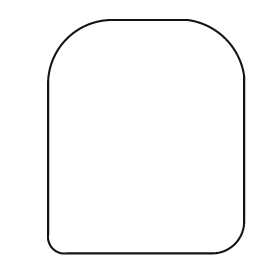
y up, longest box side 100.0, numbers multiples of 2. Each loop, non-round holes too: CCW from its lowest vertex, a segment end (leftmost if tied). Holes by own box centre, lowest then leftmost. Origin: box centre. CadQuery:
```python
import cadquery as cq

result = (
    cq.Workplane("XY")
    .moveTo(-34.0, -50.0)
    .lineTo(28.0, -50.0)
    .threePointArc((38.0, -46.0), (42.0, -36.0))
    .lineTo(42.0, 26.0)
    .threePointArc((34.0, 42.0), (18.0, 50.0))
    .lineTo(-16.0, 50.0)
    .threePointArc((-34.0, 42.0), (-42.0, 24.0))
    .lineTo(-42.0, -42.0)
    .threePointArc((-40.0, -48.0), (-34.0, -50.0))
    .close()
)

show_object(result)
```